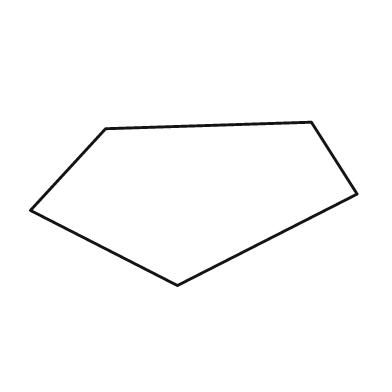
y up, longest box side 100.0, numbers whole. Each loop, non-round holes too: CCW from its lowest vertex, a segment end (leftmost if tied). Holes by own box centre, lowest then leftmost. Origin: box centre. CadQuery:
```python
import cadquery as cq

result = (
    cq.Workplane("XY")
    .moveTo(-5.0, -25.0)
    .lineTo(50.0, 3.0)
    .lineTo(36.0, 25.0)
    .lineTo(-27.0, 23.0)
    .lineTo(-50.0, -2.0)
    .close()
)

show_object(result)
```